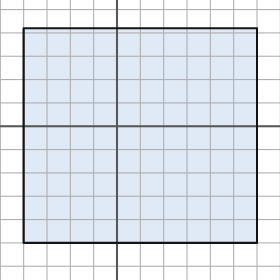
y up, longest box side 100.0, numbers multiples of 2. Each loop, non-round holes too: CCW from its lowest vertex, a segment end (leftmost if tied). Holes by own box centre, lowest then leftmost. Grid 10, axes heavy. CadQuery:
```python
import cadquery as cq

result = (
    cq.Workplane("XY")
    .moveTo(-40.0, -50.0)
    .lineTo(60.0, -50.0)
    .lineTo(60.0, 42.0)
    .lineTo(-40.0, 42.0)
    .close()
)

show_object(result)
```